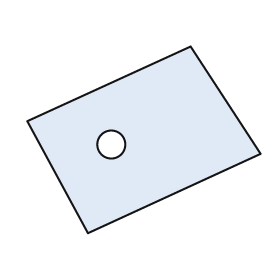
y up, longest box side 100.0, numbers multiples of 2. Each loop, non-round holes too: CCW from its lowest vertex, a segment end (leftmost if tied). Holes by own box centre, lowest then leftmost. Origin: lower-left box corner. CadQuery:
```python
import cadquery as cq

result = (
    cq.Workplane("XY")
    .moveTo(26.0, 0.0)
    .lineTo(100.0, 34.0)
    .lineTo(70.0, 80.0)
    .lineTo(0.0, 48.0)
    .close()
    .moveTo(36.0, 38.0)
    .circle(6.0)
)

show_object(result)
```